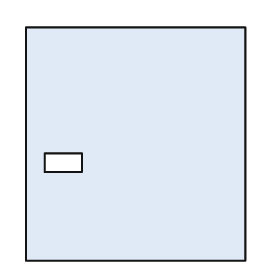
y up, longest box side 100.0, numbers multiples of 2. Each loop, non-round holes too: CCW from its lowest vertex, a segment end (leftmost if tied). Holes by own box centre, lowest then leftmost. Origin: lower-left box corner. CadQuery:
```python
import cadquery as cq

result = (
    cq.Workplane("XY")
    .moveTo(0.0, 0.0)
    .lineTo(94.0, 0.0)
    .lineTo(94.0, 100.0)
    .lineTo(0.0, 100.0)
    .close()
    .moveTo(8.0, 38.0)
    .lineTo(24.0, 38.0)
    .lineTo(24.0, 46.0)
    .lineTo(8.0, 46.0)
    .close()
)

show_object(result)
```